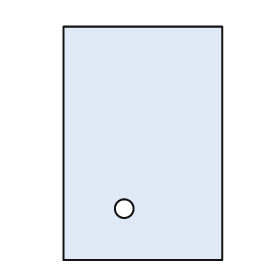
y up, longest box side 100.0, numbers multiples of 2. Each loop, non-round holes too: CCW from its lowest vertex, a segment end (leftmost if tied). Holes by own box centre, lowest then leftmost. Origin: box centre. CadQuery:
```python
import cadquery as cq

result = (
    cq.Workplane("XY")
    .moveTo(-34.0, -50.0)
    .lineTo(34.0, -50.0)
    .lineTo(34.0, 50.0)
    .lineTo(-34.0, 50.0)
    .close()
    .moveTo(-8.0, -28.0)
    .circle(4.0)
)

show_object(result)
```